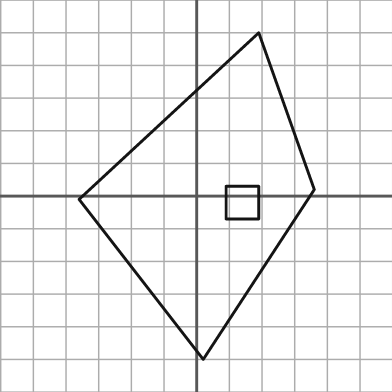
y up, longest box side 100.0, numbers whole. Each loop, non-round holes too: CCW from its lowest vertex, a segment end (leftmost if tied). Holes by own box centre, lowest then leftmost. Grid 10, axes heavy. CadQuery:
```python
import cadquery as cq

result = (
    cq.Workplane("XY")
    .moveTo(2.0, -50.0)
    .lineTo(36.0, 2.0)
    .lineTo(19.0, 50.0)
    .lineTo(-36.0, -1.0)
    .close()
    .moveTo(9.0, -7.0)
    .lineTo(19.0, -7.0)
    .lineTo(19.0, 3.0)
    .lineTo(9.0, 3.0)
    .close()
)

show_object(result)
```